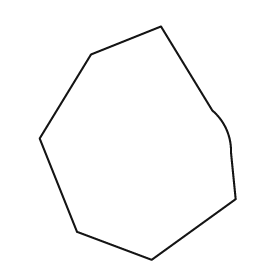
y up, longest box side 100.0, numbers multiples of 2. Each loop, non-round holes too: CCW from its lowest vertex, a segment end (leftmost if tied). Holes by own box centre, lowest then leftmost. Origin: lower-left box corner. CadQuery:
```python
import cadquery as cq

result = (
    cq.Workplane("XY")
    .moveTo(48.0, 0.0)
    .lineTo(84.0, 26.0)
    .lineTo(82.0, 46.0)
    .threePointArc((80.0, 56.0), (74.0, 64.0))
    .lineTo(52.0, 100.0)
    .lineTo(22.0, 88.0)
    .lineTo(0.0, 52.0)
    .lineTo(16.0, 12.0)
    .close()
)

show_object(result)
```